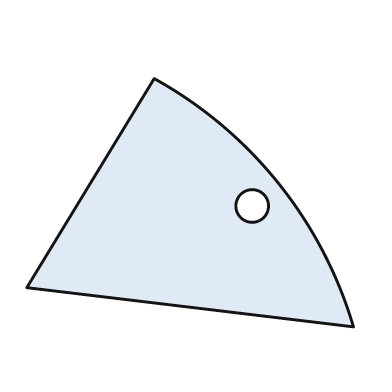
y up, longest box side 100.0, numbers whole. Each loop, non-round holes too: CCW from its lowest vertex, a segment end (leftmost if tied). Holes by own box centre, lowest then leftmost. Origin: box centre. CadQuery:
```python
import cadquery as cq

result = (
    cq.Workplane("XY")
    .moveTo(50.0, -38.0)
    .threePointArc((27.0, 6.0), (-11.0, 38.0))
    .lineTo(-50.0, -26.0)
    .close()
    .moveTo(19.0, -1.0)
    .circle(5.0)
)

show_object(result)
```